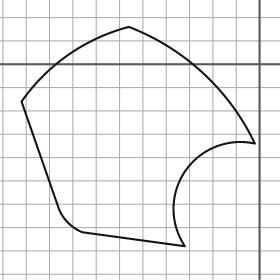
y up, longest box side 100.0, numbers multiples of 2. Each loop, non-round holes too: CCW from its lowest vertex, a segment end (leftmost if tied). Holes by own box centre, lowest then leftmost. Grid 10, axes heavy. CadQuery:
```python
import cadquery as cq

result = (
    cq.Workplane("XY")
    .moveTo(-32.0, -78.0)
    .threePointArc((-32.0, -46.0), (-2.0, -34.0))
    .threePointArc((-24.0, -4.0), (-56.0, 16.0))
    .threePointArc((-82.0, 4.0), (-102.0, -16.0))
    .lineTo(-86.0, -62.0)
    .threePointArc((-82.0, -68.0), (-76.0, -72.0))
    .close()
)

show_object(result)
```